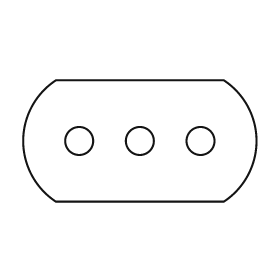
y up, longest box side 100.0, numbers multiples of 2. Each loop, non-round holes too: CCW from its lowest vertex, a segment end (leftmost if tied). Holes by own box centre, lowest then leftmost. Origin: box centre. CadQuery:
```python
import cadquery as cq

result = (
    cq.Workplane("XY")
    .moveTo(-36.0, -26.0)
    .lineTo(36.0, -26.0)
    .threePointArc((50.0, 0.0), (36.0, 26.0))
    .lineTo(-36.0, 26.0)
    .threePointArc((-50.0, 0.0), (-36.0, -26.0))
    .close()
    .moveTo(-26.0, 0.0)
    .circle(6.0)
    .moveTo(0.0, 0.0)
    .circle(6.0)
    .moveTo(26.0, 0.0)
    .circle(6.0)
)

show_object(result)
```